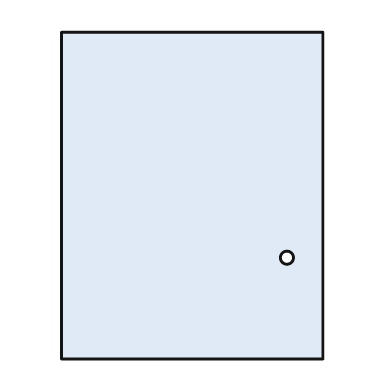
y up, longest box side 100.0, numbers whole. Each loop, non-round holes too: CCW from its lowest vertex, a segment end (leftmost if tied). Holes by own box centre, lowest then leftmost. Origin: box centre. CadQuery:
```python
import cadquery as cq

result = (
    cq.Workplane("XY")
    .moveTo(-40.0, -50.0)
    .lineTo(40.0, -50.0)
    .lineTo(40.0, 50.0)
    .lineTo(-40.0, 50.0)
    .close()
    .moveTo(29.0, -19.0)
    .circle(2.0)
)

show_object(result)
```